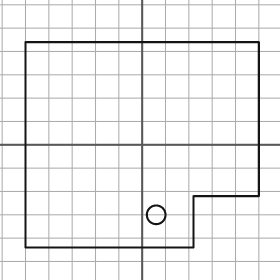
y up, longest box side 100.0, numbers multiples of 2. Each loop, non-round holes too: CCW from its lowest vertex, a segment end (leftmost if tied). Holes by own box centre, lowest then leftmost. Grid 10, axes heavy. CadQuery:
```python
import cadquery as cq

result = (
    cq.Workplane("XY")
    .moveTo(-50.0, -44.0)
    .lineTo(22.0, -44.0)
    .lineTo(22.0, -22.0)
    .lineTo(50.0, -22.0)
    .lineTo(50.0, 44.0)
    .lineTo(-50.0, 44.0)
    .close()
    .moveTo(6.0, -30.0)
    .circle(4.0)
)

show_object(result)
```